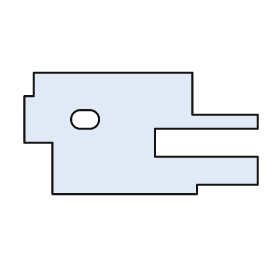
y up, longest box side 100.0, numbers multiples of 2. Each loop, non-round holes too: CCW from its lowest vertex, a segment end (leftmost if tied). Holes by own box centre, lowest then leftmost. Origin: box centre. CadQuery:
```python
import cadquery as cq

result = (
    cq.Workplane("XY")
    .moveTo(-38.0, -26.0)
    .lineTo(24.0, -26.0)
    .lineTo(24.0, -22.0)
    .lineTo(50.0, -22.0)
    .lineTo(50.0, -10.0)
    .lineTo(6.0, -10.0)
    .lineTo(6.0, 2.0)
    .lineTo(50.0, 2.0)
    .lineTo(50.0, 8.0)
    .lineTo(22.0, 8.0)
    .lineTo(22.0, 26.0)
    .lineTo(-46.0, 26.0)
    .lineTo(-46.0, 16.0)
    .lineTo(-50.0, 16.0)
    .lineTo(-50.0, -4.0)
    .lineTo(-38.0, -4.0)
    .close()
    .moveTo(-26.0, 2.0)
    .lineTo(-22.0, 2.0)
    .threePointArc((-18.0, 6.0), (-22.0, 10.0))
    .lineTo(-26.0, 10.0)
    .threePointArc((-30.0, 6.0), (-26.0, 2.0))
    .close()
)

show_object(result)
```